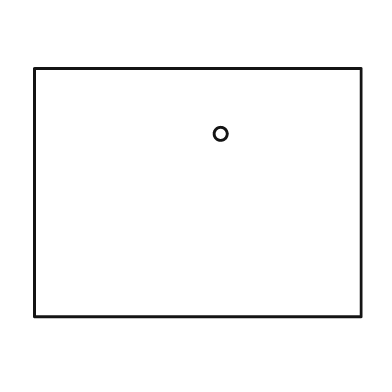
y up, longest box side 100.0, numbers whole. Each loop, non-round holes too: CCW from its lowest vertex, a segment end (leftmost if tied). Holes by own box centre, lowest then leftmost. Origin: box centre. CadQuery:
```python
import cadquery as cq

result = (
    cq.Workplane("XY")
    .moveTo(-50.0, -38.0)
    .lineTo(50.0, -38.0)
    .lineTo(50.0, 38.0)
    .lineTo(-50.0, 38.0)
    .close()
    .moveTo(7.0, 18.0)
    .circle(2.0)
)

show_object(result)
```